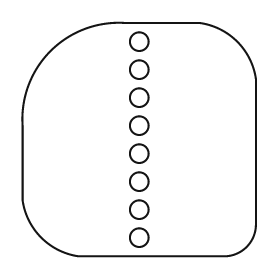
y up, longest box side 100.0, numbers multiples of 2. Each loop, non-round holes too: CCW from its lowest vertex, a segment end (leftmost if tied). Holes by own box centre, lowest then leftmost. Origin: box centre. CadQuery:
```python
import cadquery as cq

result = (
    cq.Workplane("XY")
    .moveTo(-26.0, -50.0)
    .lineTo(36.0, -50.0)
    .threePointArc((46.0, -46.0), (50.0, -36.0))
    .lineTo(50.0, 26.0)
    .threePointArc((42.0, 42.0), (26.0, 50.0))
    .lineTo(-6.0, 50.0)
    .threePointArc((-38.0, 38.0), (-50.0, 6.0))
    .lineTo(-50.0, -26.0)
    .threePointArc((-42.0, -42.0), (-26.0, -50.0))
    .close()
    .moveTo(0.0, -42.0)
    .circle(4.0)
    .moveTo(0.0, -30.0)
    .circle(4.0)
    .moveTo(0.0, -18.0)
    .circle(4.0)
    .moveTo(0.0, -6.0)
    .circle(4.0)
    .moveTo(0.0, 6.0)
    .circle(4.0)
    .moveTo(0.0, 18.0)
    .circle(4.0)
    .moveTo(0.0, 30.0)
    .circle(4.0)
    .moveTo(0.0, 42.0)
    .circle(4.0)
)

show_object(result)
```